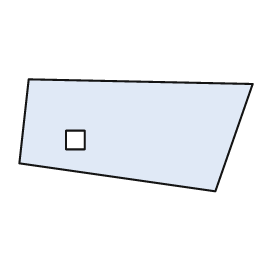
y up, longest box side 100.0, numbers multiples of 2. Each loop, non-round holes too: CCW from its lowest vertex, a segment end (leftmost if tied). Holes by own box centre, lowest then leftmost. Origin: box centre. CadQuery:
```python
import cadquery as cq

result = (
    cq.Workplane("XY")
    .moveTo(34.0, -24.0)
    .lineTo(50.0, 22.0)
    .lineTo(-46.0, 24.0)
    .lineTo(-50.0, -12.0)
    .close()
    .moveTo(-30.0, -6.0)
    .lineTo(-22.0, -6.0)
    .lineTo(-22.0, 2.0)
    .lineTo(-30.0, 2.0)
    .close()
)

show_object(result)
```